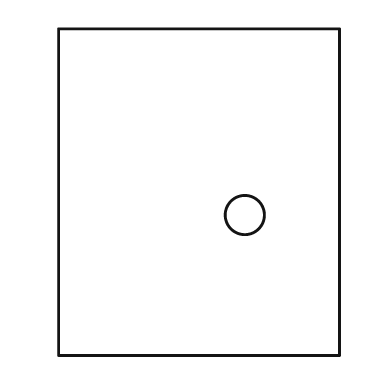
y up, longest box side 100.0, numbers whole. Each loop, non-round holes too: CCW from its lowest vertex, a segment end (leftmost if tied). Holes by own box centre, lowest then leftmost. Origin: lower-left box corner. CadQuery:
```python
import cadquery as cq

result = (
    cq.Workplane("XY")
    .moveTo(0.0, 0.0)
    .lineTo(86.0, 0.0)
    .lineTo(86.0, 100.0)
    .lineTo(0.0, 100.0)
    .close()
    .moveTo(57.0, 43.0)
    .circle(6.0)
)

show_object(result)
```